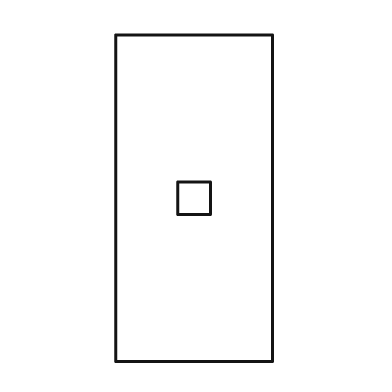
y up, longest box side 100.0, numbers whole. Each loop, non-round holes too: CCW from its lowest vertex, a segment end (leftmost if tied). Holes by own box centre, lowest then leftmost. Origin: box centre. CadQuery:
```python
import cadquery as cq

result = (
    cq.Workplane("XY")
    .moveTo(-24.0, -50.0)
    .lineTo(24.0, -50.0)
    .lineTo(24.0, 50.0)
    .lineTo(-24.0, 50.0)
    .close()
    .moveTo(-5.0, -5.0)
    .lineTo(5.0, -5.0)
    .lineTo(5.0, 5.0)
    .lineTo(-5.0, 5.0)
    .close()
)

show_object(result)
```